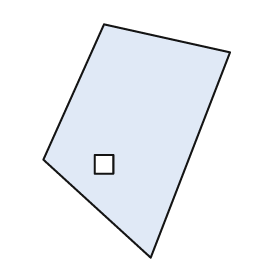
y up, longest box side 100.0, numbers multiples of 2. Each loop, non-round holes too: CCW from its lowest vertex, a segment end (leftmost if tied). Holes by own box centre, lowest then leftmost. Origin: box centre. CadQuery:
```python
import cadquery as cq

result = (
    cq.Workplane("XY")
    .moveTo(6.0, -50.0)
    .lineTo(40.0, 38.0)
    .lineTo(-14.0, 50.0)
    .lineTo(-40.0, -8.0)
    .close()
    .moveTo(-18.0, -14.0)
    .lineTo(-10.0, -14.0)
    .lineTo(-10.0, -6.0)
    .lineTo(-18.0, -6.0)
    .close()
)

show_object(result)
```